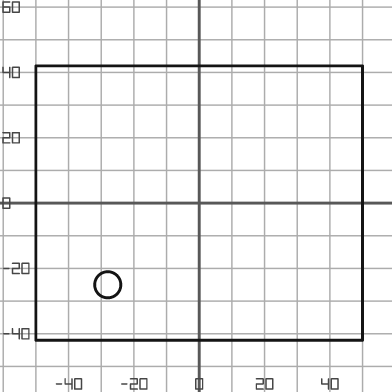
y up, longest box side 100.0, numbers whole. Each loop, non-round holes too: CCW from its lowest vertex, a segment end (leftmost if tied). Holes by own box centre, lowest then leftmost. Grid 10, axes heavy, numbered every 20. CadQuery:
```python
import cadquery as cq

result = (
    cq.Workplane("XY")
    .moveTo(-50.0, -42.0)
    .lineTo(50.0, -42.0)
    .lineTo(50.0, 42.0)
    .lineTo(-50.0, 42.0)
    .close()
    .moveTo(-28.0, -25.0)
    .circle(4.0)
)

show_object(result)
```